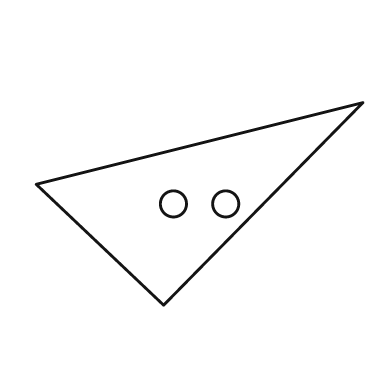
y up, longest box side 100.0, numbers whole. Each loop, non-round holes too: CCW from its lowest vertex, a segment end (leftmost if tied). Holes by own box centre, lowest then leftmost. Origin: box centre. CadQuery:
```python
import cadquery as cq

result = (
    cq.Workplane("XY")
    .moveTo(-11.0, -31.0)
    .lineTo(50.0, 31.0)
    .lineTo(-50.0, 6.0)
    .close()
    .moveTo(-8.0, 0.0)
    .circle(4.0)
    .moveTo(8.0, 0.0)
    .circle(4.0)
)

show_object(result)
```